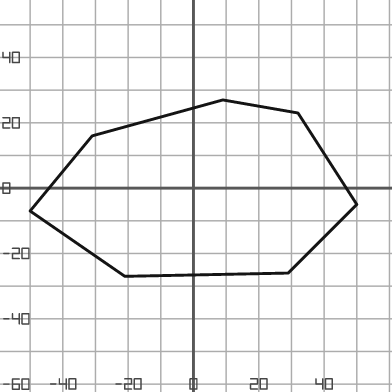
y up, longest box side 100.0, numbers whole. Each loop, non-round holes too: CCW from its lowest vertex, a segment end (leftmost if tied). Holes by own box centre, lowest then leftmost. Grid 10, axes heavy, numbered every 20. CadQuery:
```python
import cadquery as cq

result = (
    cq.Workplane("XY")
    .moveTo(-21.0, -27.0)
    .lineTo(29.0, -26.0)
    .lineTo(50.0, -5.0)
    .lineTo(32.0, 23.0)
    .lineTo(9.0, 27.0)
    .lineTo(-31.0, 16.0)
    .lineTo(-50.0, -7.0)
    .close()
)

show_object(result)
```